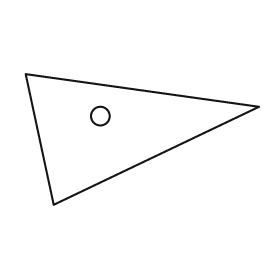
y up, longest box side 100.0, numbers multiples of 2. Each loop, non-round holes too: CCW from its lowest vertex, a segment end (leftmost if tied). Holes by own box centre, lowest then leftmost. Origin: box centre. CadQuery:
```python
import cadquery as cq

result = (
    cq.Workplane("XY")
    .moveTo(-38.0, -28.0)
    .lineTo(50.0, 14.0)
    .lineTo(-50.0, 28.0)
    .close()
    .moveTo(-18.0, 10.0)
    .circle(4.0)
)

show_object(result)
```